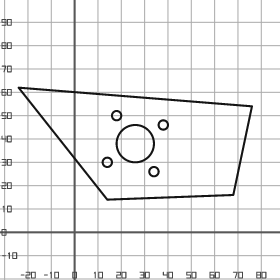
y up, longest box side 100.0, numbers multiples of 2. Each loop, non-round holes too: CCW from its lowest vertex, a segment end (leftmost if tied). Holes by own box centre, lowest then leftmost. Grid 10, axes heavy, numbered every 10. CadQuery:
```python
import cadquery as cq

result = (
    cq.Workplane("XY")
    .moveTo(14.0, 14.0)
    .lineTo(68.0, 16.0)
    .lineTo(76.0, 54.0)
    .lineTo(-24.0, 62.0)
    .close()
    .moveTo(34.0, 26.0)
    .circle(2.0)
    .moveTo(14.0, 30.0)
    .circle(2.0)
    .moveTo(26.0, 38.0)
    .circle(8.0)
    .moveTo(38.0, 46.0)
    .circle(2.0)
    .moveTo(18.0, 50.0)
    .circle(2.0)
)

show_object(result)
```